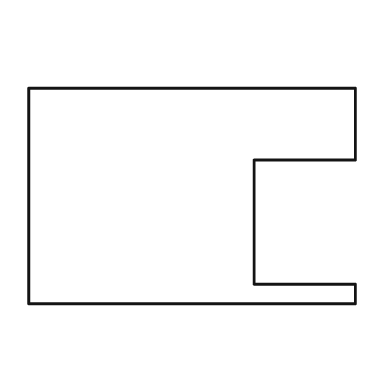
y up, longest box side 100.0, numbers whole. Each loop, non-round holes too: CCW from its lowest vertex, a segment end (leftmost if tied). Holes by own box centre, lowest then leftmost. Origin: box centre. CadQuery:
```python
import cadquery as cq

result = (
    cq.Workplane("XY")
    .moveTo(-50.0, -33.0)
    .lineTo(50.0, -33.0)
    .lineTo(50.0, -27.0)
    .lineTo(19.0, -27.0)
    .lineTo(19.0, 11.0)
    .lineTo(50.0, 11.0)
    .lineTo(50.0, 33.0)
    .lineTo(-50.0, 33.0)
    .close()
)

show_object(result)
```